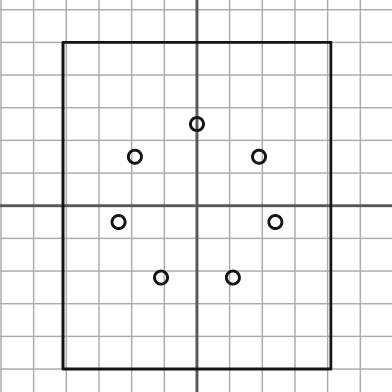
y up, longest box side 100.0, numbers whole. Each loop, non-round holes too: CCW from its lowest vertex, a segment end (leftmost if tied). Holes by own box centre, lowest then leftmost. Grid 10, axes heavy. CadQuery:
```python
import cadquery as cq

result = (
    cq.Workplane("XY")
    .moveTo(-41.0, -50.0)
    .lineTo(41.0, -50.0)
    .lineTo(41.0, 50.0)
    .lineTo(-41.0, 50.0)
    .close()
    .moveTo(-11.0, -22.0)
    .circle(2.0)
    .moveTo(11.0, -22.0)
    .circle(2.0)
    .moveTo(-24.0, -5.0)
    .circle(2.0)
    .moveTo(24.0, -5.0)
    .circle(2.0)
    .moveTo(-19.0, 15.0)
    .circle(2.0)
    .moveTo(19.0, 15.0)
    .circle(2.0)
    .moveTo(0.0, 25.0)
    .circle(2.0)
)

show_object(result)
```